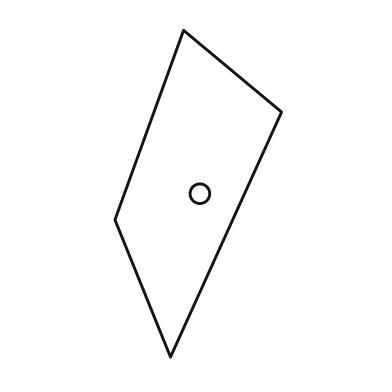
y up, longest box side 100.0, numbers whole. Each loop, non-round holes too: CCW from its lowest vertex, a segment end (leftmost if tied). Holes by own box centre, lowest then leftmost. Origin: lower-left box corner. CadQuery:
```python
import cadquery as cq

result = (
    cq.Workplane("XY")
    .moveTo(17.0, 0.0)
    .lineTo(51.0, 75.0)
    .lineTo(21.0, 100.0)
    .lineTo(0.0, 42.0)
    .close()
    .moveTo(26.0, 50.0)
    .circle(3.0)
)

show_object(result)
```